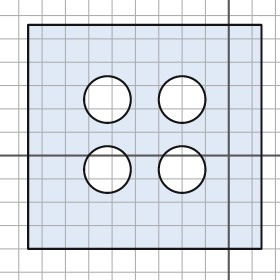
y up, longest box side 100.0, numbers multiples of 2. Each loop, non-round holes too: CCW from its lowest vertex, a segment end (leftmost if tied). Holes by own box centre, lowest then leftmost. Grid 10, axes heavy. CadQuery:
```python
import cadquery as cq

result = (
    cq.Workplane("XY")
    .moveTo(-86.0, -40.0)
    .lineTo(14.0, -40.0)
    .lineTo(14.0, 56.0)
    .lineTo(-86.0, 56.0)
    .close()
    .moveTo(-52.0, -6.0)
    .circle(10.0)
    .moveTo(-20.0, -6.0)
    .circle(10.0)
    .moveTo(-52.0, 24.0)
    .circle(10.0)
    .moveTo(-20.0, 24.0)
    .circle(10.0)
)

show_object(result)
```